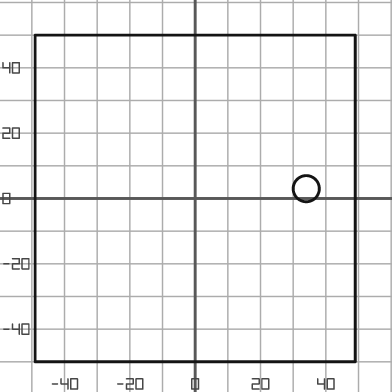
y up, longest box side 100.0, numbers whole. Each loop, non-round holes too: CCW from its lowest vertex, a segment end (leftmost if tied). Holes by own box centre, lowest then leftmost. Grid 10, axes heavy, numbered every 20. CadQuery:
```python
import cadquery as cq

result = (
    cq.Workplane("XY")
    .moveTo(-49.0, -50.0)
    .lineTo(49.0, -50.0)
    .lineTo(49.0, 50.0)
    .lineTo(-49.0, 50.0)
    .close()
    .moveTo(34.0, 3.0)
    .circle(4.0)
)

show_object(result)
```